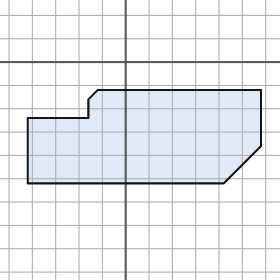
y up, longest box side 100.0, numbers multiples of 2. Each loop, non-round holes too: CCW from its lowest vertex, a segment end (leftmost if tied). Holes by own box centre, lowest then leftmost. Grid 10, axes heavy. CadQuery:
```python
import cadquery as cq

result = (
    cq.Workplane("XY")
    .moveTo(-42.0, -52.0)
    .lineTo(42.0, -52.0)
    .lineTo(58.0, -36.0)
    .lineTo(58.0, -12.0)
    .lineTo(-12.0, -12.0)
    .lineTo(-16.0, -16.0)
    .lineTo(-16.0, -24.0)
    .lineTo(-42.0, -24.0)
    .close()
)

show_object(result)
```